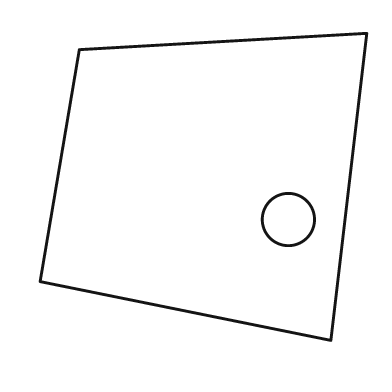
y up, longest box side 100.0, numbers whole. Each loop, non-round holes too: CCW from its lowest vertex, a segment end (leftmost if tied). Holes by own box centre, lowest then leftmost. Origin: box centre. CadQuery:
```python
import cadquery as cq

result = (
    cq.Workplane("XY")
    .moveTo(39.0, -47.0)
    .lineTo(50.0, 47.0)
    .lineTo(-38.0, 42.0)
    .lineTo(-50.0, -29.0)
    .close()
    .moveTo(26.0, -10.0)
    .circle(8.0)
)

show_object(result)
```